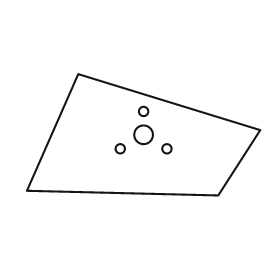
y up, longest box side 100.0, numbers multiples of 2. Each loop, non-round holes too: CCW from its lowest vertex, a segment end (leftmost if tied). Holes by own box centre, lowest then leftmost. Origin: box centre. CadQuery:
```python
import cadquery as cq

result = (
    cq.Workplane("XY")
    .moveTo(32.0, -26.0)
    .lineTo(50.0, 2.0)
    .lineTo(-28.0, 26.0)
    .lineTo(-50.0, -24.0)
    .close()
    .moveTo(-10.0, -6.0)
    .circle(2.0)
    .moveTo(10.0, -6.0)
    .circle(2.0)
    .moveTo(0.0, 0.0)
    .circle(4.0)
    .moveTo(0.0, 10.0)
    .circle(2.0)
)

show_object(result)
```